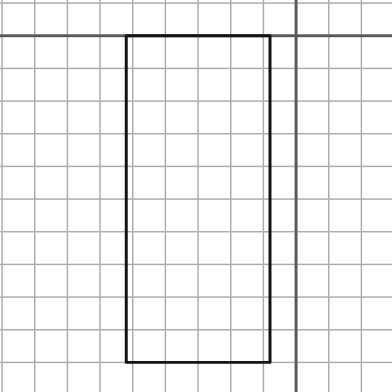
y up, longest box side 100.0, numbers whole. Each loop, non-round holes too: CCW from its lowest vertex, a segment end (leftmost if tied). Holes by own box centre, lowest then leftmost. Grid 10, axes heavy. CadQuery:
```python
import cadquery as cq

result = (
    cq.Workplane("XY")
    .moveTo(-52.0, -100.0)
    .lineTo(-8.0, -100.0)
    .lineTo(-8.0, 0.0)
    .lineTo(-52.0, 0.0)
    .close()
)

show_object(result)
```